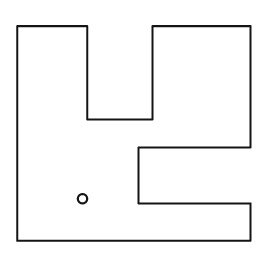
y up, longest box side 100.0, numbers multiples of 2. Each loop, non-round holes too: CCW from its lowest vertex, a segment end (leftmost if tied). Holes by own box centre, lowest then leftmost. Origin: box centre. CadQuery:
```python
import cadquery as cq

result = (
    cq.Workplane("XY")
    .moveTo(-50.0, -46.0)
    .lineTo(50.0, -46.0)
    .lineTo(50.0, -30.0)
    .lineTo(2.0, -30.0)
    .lineTo(2.0, -6.0)
    .lineTo(50.0, -6.0)
    .lineTo(50.0, 46.0)
    .lineTo(8.0, 46.0)
    .lineTo(8.0, 6.0)
    .lineTo(-20.0, 6.0)
    .lineTo(-20.0, 46.0)
    .lineTo(-50.0, 46.0)
    .close()
    .moveTo(-22.0, -28.0)
    .circle(2.0)
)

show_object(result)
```